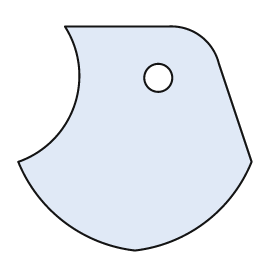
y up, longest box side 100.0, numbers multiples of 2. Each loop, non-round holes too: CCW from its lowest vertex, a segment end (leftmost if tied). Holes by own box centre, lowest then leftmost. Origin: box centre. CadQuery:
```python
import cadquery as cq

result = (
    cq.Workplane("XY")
    .moveTo(0.0, -48.0)
    .threePointArc((30.0, -36.0), (50.0, -10.0))
    .lineTo(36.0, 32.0)
    .threePointArc((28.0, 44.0), (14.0, 48.0))
    .lineTo(-30.0, 48.0)
    .threePointArc((-26.0, 14.0), (-50.0, -10.0))
    .threePointArc((-30.0, -36.0), (0.0, -48.0))
    .close()
    .moveTo(10.0, 26.0)
    .circle(6.0)
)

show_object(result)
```